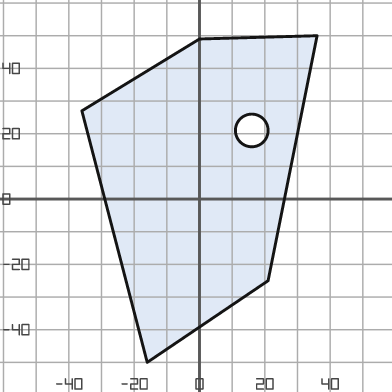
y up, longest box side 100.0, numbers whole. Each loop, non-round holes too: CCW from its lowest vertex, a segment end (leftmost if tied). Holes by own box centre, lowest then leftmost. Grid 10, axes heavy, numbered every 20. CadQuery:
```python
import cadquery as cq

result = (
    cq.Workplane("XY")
    .moveTo(-16.0, -50.0)
    .lineTo(21.0, -25.0)
    .lineTo(36.0, 50.0)
    .lineTo(0.0, 49.0)
    .lineTo(-36.0, 27.0)
    .close()
    .moveTo(16.0, 21.0)
    .circle(5.0)
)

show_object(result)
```